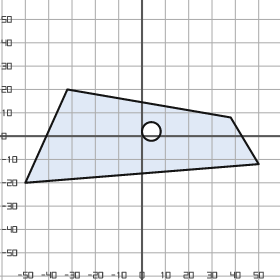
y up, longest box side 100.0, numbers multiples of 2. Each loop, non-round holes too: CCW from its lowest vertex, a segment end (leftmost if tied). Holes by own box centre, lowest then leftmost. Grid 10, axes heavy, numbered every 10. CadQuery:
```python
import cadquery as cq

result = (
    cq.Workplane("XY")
    .moveTo(-50.0, -20.0)
    .lineTo(50.0, -12.0)
    .lineTo(38.0, 8.0)
    .lineTo(-32.0, 20.0)
    .close()
    .moveTo(4.0, 2.0)
    .circle(4.0)
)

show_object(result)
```